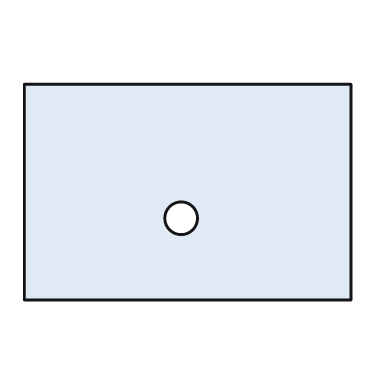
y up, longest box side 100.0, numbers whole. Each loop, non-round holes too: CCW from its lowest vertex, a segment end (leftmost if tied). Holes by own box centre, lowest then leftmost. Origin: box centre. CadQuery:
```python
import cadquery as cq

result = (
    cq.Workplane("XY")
    .moveTo(-50.0, -33.0)
    .lineTo(50.0, -33.0)
    .lineTo(50.0, 33.0)
    .lineTo(-50.0, 33.0)
    .close()
    .moveTo(-2.0, -8.0)
    .circle(5.0)
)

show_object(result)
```